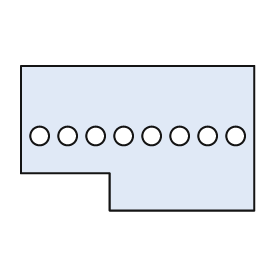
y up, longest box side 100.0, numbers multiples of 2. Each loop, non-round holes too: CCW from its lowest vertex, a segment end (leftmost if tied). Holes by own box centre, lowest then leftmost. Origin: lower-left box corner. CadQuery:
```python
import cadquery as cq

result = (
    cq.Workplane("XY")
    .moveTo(38.0, 0.0)
    .lineTo(100.0, 0.0)
    .lineTo(100.0, 62.0)
    .lineTo(0.0, 62.0)
    .lineTo(0.0, 16.0)
    .lineTo(38.0, 16.0)
    .close()
    .moveTo(8.0, 32.0)
    .circle(4.0)
    .moveTo(20.0, 32.0)
    .circle(4.0)
    .moveTo(32.0, 32.0)
    .circle(4.0)
    .moveTo(44.0, 32.0)
    .circle(4.0)
    .moveTo(56.0, 32.0)
    .circle(4.0)
    .moveTo(68.0, 32.0)
    .circle(4.0)
    .moveTo(80.0, 32.0)
    .circle(4.0)
    .moveTo(92.0, 32.0)
    .circle(4.0)
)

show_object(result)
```